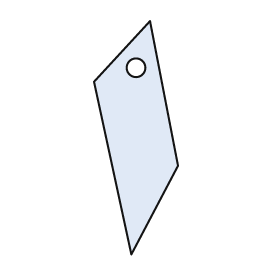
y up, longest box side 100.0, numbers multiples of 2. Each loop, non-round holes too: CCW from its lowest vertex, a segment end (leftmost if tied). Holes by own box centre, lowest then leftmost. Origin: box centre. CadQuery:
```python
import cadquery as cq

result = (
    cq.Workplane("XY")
    .moveTo(-2.0, -50.0)
    .lineTo(18.0, -12.0)
    .lineTo(6.0, 50.0)
    .lineTo(-18.0, 24.0)
    .close()
    .moveTo(0.0, 30.0)
    .circle(4.0)
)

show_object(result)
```